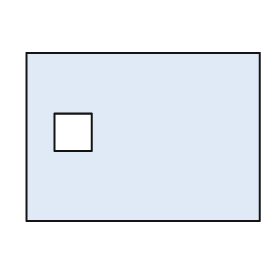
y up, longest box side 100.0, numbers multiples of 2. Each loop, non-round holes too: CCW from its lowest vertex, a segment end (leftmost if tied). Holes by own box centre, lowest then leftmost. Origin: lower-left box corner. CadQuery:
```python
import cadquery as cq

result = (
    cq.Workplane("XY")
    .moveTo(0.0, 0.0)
    .lineTo(100.0, 0.0)
    .lineTo(100.0, 72.0)
    .lineTo(0.0, 72.0)
    .close()
    .moveTo(12.0, 30.0)
    .lineTo(28.0, 30.0)
    .lineTo(28.0, 46.0)
    .lineTo(12.0, 46.0)
    .close()
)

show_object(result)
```